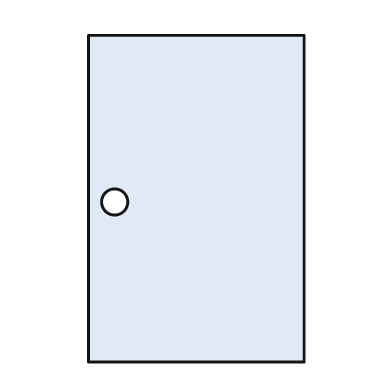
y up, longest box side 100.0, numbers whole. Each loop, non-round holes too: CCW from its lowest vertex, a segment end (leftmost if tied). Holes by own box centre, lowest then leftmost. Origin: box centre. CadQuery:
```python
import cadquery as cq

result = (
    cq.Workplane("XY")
    .moveTo(-33.0, -50.0)
    .lineTo(33.0, -50.0)
    .lineTo(33.0, 50.0)
    .lineTo(-33.0, 50.0)
    .close()
    .moveTo(-25.0, -1.0)
    .circle(4.0)
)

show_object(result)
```